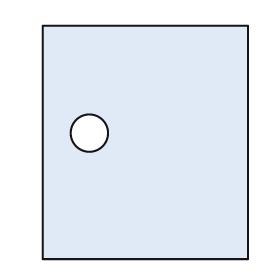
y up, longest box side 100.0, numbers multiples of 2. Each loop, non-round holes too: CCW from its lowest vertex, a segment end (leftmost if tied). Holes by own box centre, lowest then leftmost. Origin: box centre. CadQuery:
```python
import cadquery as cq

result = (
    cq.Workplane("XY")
    .moveTo(-44.0, -50.0)
    .lineTo(44.0, -50.0)
    .lineTo(44.0, 50.0)
    .lineTo(-44.0, 50.0)
    .close()
    .moveTo(-24.0, 4.0)
    .circle(8.0)
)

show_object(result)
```